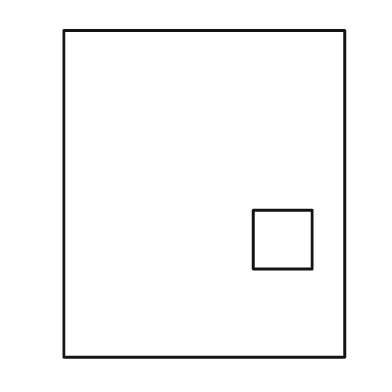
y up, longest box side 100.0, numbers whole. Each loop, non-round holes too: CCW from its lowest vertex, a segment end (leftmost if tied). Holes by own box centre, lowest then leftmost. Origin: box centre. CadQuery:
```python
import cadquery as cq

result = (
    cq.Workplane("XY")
    .moveTo(-43.0, -50.0)
    .lineTo(43.0, -50.0)
    .lineTo(43.0, 50.0)
    .lineTo(-43.0, 50.0)
    .close()
    .moveTo(15.0, -23.0)
    .lineTo(33.0, -23.0)
    .lineTo(33.0, -5.0)
    .lineTo(15.0, -5.0)
    .close()
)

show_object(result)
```